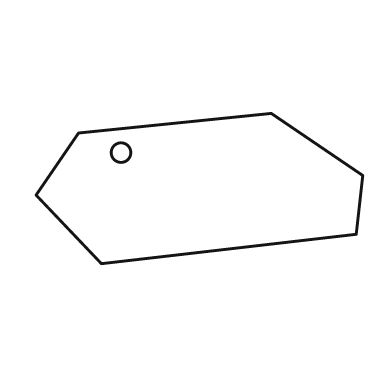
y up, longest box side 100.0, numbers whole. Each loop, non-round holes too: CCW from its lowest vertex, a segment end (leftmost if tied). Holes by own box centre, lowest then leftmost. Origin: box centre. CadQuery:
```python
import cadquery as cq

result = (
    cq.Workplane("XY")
    .moveTo(-30.0, -23.0)
    .lineTo(48.0, -14.0)
    .lineTo(50.0, 4.0)
    .lineTo(22.0, 23.0)
    .lineTo(-37.0, 17.0)
    .lineTo(-50.0, -2.0)
    .close()
    .moveTo(-24.0, 11.0)
    .circle(3.0)
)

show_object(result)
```